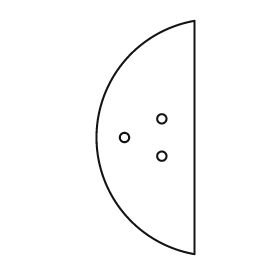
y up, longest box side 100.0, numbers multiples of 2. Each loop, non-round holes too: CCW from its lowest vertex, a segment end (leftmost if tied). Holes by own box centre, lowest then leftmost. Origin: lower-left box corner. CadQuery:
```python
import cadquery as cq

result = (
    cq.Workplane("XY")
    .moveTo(42.0, 0.0)
    .lineTo(42.0, 100.0)
    .threePointArc((0.0, 50.0), (42.0, 0.0))
    .close()
    .moveTo(28.0, 42.0)
    .circle(2.0)
    .moveTo(12.0, 50.0)
    .circle(2.0)
    .moveTo(28.0, 58.0)
    .circle(2.0)
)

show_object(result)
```